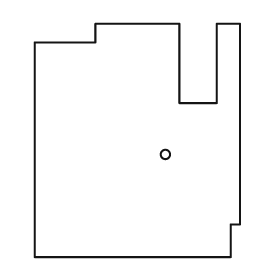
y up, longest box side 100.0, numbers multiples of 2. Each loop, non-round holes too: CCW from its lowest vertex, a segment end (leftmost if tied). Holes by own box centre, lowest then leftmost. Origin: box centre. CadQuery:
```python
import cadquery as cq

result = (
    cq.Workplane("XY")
    .moveTo(-44.0, -50.0)
    .lineTo(40.0, -50.0)
    .lineTo(40.0, -36.0)
    .lineTo(44.0, -36.0)
    .lineTo(44.0, 50.0)
    .lineTo(34.0, 50.0)
    .lineTo(34.0, 16.0)
    .lineTo(18.0, 16.0)
    .lineTo(18.0, 50.0)
    .lineTo(-18.0, 50.0)
    .lineTo(-18.0, 42.0)
    .lineTo(-44.0, 42.0)
    .close()
    .moveTo(12.0, -6.0)
    .circle(2.0)
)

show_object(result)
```